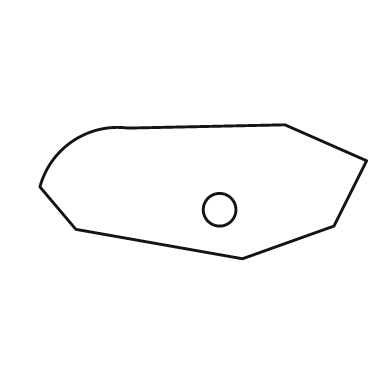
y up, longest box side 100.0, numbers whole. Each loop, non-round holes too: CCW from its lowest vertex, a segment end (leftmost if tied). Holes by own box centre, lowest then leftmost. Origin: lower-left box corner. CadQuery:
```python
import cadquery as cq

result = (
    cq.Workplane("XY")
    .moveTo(62.0, 0.0)
    .lineTo(90.0, 10.0)
    .lineTo(100.0, 30.0)
    .lineTo(75.0, 41.0)
    .lineTo(27.0, 40.0)
    .threePointArc((10.0, 36.0), (0.0, 22.0))
    .lineTo(11.0, 9.0)
    .close()
    .moveTo(55.0, 15.0)
    .circle(5.0)
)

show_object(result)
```